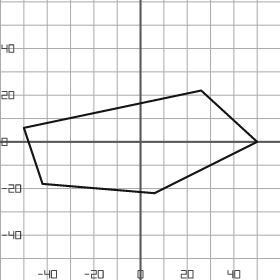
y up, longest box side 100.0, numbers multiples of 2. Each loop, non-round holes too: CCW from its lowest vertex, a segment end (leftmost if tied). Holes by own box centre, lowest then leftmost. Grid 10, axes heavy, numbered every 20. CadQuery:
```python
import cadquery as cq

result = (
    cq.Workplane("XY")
    .moveTo(6.0, -22.0)
    .lineTo(50.0, 0.0)
    .lineTo(26.0, 22.0)
    .lineTo(-50.0, 6.0)
    .lineTo(-42.0, -18.0)
    .close()
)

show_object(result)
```